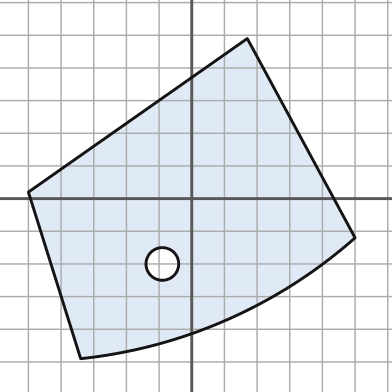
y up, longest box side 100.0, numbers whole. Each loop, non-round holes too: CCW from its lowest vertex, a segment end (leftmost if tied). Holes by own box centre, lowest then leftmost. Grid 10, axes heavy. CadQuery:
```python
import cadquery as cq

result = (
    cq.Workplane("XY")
    .moveTo(-34.0, -49.0)
    .threePointArc((11.0, -37.0), (50.0, -12.0))
    .lineTo(17.0, 49.0)
    .lineTo(-50.0, 2.0)
    .close()
    .moveTo(-9.0, -20.0)
    .circle(5.0)
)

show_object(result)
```